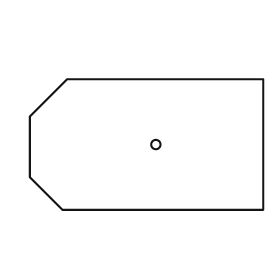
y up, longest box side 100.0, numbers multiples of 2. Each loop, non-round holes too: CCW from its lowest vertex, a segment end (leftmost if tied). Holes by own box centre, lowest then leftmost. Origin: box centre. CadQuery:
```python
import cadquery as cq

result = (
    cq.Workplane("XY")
    .moveTo(-36.0, -28.0)
    .lineTo(50.0, -28.0)
    .lineTo(50.0, 28.0)
    .lineTo(-34.0, 28.0)
    .lineTo(-50.0, 12.0)
    .lineTo(-50.0, -14.0)
    .close()
    .moveTo(4.0, 0.0)
    .circle(2.0)
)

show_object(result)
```